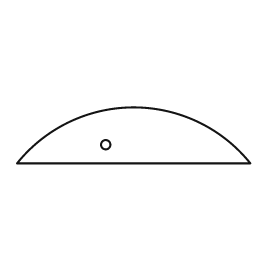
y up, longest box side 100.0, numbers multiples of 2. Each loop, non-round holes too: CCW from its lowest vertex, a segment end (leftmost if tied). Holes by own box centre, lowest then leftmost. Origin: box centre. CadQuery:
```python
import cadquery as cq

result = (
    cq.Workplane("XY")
    .moveTo(-50.0, -12.0)
    .lineTo(50.0, -12.0)
    .threePointArc((0.0, 12.0), (-50.0, -12.0))
    .close()
    .moveTo(-12.0, -4.0)
    .circle(2.0)
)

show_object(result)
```